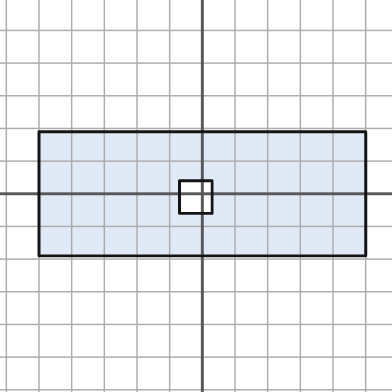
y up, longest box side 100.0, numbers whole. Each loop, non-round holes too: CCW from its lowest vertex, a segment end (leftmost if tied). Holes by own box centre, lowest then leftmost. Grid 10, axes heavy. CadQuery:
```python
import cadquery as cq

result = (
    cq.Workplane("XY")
    .moveTo(-50.0, -19.0)
    .lineTo(50.0, -19.0)
    .lineTo(50.0, 19.0)
    .lineTo(-50.0, 19.0)
    .close()
    .moveTo(-7.0, -6.0)
    .lineTo(3.0, -6.0)
    .lineTo(3.0, 4.0)
    .lineTo(-7.0, 4.0)
    .close()
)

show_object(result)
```